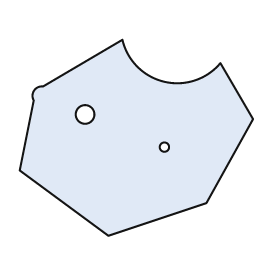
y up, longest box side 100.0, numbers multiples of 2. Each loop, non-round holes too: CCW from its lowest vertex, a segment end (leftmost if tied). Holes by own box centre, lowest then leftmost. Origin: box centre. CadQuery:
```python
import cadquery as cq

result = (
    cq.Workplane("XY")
    .moveTo(-12.0, -42.0)
    .lineTo(30.0, -28.0)
    .lineTo(50.0, 8.0)
    .lineTo(36.0, 32.0)
    .threePointArc((12.0, 24.0), (-6.0, 42.0))
    .lineTo(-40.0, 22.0)
    .threePointArc((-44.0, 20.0), (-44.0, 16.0))
    .lineTo(-50.0, -14.0)
    .close()
    .moveTo(12.0, -4.0)
    .circle(2.0)
    .moveTo(-22.0, 10.0)
    .circle(4.0)
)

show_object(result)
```